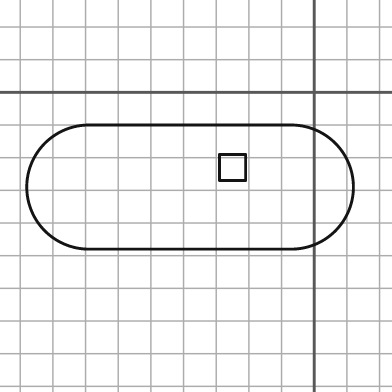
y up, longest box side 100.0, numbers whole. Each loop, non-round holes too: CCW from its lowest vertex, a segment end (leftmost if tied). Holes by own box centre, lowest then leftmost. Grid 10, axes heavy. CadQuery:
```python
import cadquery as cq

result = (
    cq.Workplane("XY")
    .moveTo(-69.0, -48.0)
    .lineTo(-7.0, -48.0)
    .threePointArc((12.0, -29.0), (-7.0, -10.0))
    .lineTo(-69.0, -10.0)
    .threePointArc((-88.0, -29.0), (-69.0, -48.0))
    .close()
    .moveTo(-29.0, -27.0)
    .lineTo(-21.0, -27.0)
    .lineTo(-21.0, -19.0)
    .lineTo(-29.0, -19.0)
    .close()
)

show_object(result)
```